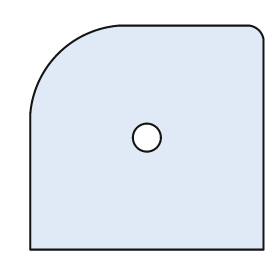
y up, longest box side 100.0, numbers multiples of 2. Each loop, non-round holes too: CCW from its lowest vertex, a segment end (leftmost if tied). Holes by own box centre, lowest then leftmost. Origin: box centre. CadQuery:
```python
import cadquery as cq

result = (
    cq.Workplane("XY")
    .moveTo(-50.0, -48.0)
    .lineTo(50.0, -48.0)
    .lineTo(50.0, 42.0)
    .threePointArc((48.0, 46.0), (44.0, 48.0))
    .lineTo(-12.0, 48.0)
    .threePointArc((-38.0, 36.0), (-50.0, 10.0))
    .close()
    .moveTo(0.0, 0.0)
    .circle(6.0)
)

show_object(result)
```